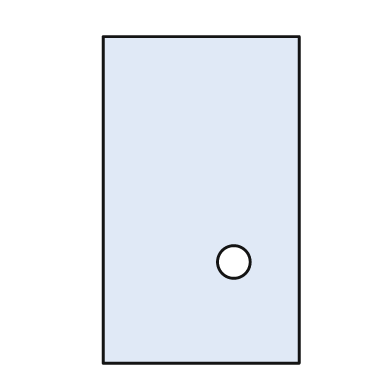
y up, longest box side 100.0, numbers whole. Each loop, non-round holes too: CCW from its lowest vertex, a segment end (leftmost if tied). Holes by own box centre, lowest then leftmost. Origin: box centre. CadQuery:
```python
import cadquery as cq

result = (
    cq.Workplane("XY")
    .moveTo(-30.0, -50.0)
    .lineTo(30.0, -50.0)
    .lineTo(30.0, 50.0)
    .lineTo(-30.0, 50.0)
    .close()
    .moveTo(10.0, -19.0)
    .circle(5.0)
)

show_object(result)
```